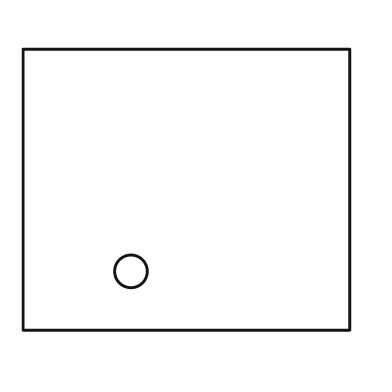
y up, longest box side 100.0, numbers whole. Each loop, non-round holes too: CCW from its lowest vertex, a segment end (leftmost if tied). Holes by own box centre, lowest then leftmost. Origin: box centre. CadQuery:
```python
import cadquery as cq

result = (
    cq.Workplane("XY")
    .moveTo(-50.0, -43.0)
    .lineTo(50.0, -43.0)
    .lineTo(50.0, 43.0)
    .lineTo(-50.0, 43.0)
    .close()
    .moveTo(-17.0, -25.0)
    .circle(5.0)
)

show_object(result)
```